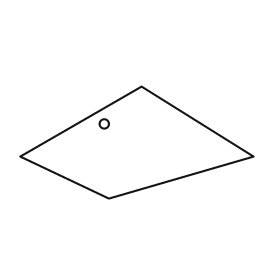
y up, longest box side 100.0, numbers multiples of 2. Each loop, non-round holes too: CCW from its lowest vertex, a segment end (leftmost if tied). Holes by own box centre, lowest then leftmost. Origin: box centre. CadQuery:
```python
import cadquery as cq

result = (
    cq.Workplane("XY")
    .moveTo(-12.0, -24.0)
    .lineTo(50.0, -6.0)
    .lineTo(2.0, 24.0)
    .lineTo(-50.0, -6.0)
    .close()
    .moveTo(-14.0, 8.0)
    .circle(2.0)
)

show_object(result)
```